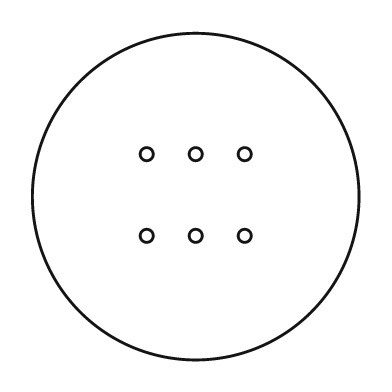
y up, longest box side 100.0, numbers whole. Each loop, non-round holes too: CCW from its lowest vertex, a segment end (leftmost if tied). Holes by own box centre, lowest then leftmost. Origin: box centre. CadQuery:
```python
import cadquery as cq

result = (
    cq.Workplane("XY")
    .moveTo(0.0, 0.0)
    .circle(50.0)
    .moveTo(-15.0, -12.0)
    .circle(2.0)
    .moveTo(0.0, -12.0)
    .circle(2.0)
    .moveTo(15.0, -12.0)
    .circle(2.0)
    .moveTo(-15.0, 13.0)
    .circle(2.0)
    .moveTo(0.0, 13.0)
    .circle(2.0)
    .moveTo(15.0, 13.0)
    .circle(2.0)
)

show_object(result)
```